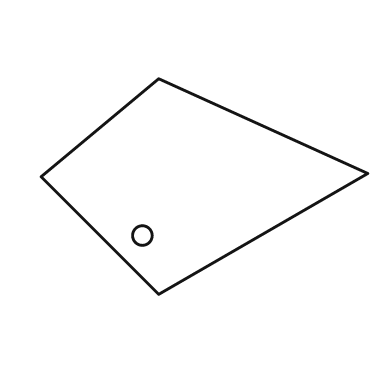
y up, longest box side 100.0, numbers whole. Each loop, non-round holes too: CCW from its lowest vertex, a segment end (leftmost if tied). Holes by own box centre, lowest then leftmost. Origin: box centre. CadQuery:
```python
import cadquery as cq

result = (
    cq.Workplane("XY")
    .moveTo(-14.0, -33.0)
    .lineTo(50.0, 4.0)
    .lineTo(-14.0, 33.0)
    .lineTo(-50.0, 3.0)
    .close()
    .moveTo(-19.0, -15.0)
    .circle(3.0)
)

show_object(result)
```